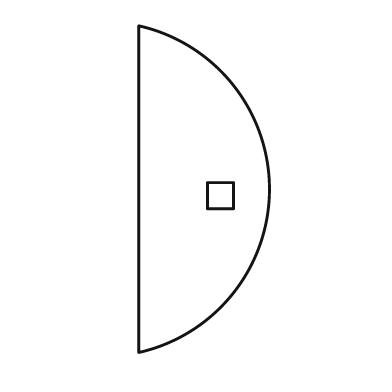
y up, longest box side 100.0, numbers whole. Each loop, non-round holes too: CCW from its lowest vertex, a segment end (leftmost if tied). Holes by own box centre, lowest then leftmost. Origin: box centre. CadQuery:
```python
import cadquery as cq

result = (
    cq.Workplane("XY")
    .moveTo(-20.0, -50.0)
    .threePointArc((20.0, 0.0), (-20.0, 50.0))
    .close()
    .moveTo(1.0, -6.0)
    .lineTo(9.0, -6.0)
    .lineTo(9.0, 2.0)
    .lineTo(1.0, 2.0)
    .close()
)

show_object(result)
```